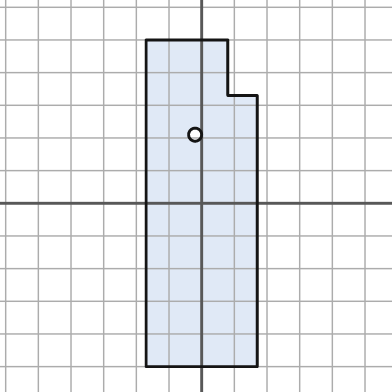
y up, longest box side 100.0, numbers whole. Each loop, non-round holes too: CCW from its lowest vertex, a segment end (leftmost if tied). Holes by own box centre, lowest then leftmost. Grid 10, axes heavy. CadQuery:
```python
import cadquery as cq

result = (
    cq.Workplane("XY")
    .moveTo(-17.0, -50.0)
    .lineTo(17.0, -50.0)
    .lineTo(17.0, 33.0)
    .lineTo(8.0, 33.0)
    .lineTo(8.0, 50.0)
    .lineTo(-17.0, 50.0)
    .close()
    .moveTo(-2.0, 21.0)
    .circle(2.0)
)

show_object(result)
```